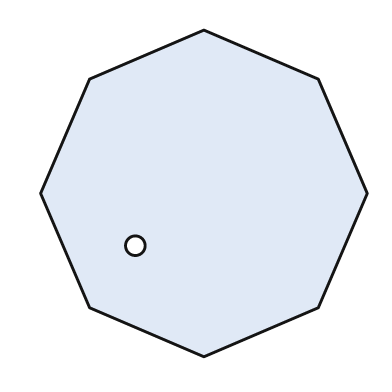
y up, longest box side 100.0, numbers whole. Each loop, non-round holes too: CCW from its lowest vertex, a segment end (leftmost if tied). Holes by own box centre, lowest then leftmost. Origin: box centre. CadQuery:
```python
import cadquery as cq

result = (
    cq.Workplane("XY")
    .moveTo(0.0, -50.0)
    .lineTo(35.0, -35.0)
    .lineTo(50.0, 0.0)
    .lineTo(35.0, 35.0)
    .lineTo(0.0, 50.0)
    .lineTo(-35.0, 35.0)
    .lineTo(-50.0, 0.0)
    .lineTo(-35.0, -35.0)
    .close()
    .moveTo(-21.0, -16.0)
    .circle(3.0)
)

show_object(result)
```